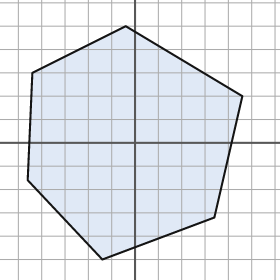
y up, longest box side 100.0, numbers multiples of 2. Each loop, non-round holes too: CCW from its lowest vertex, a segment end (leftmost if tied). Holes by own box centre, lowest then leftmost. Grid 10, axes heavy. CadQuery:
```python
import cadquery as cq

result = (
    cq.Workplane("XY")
    .moveTo(-14.0, -50.0)
    .lineTo(34.0, -32.0)
    .lineTo(46.0, 20.0)
    .lineTo(-4.0, 50.0)
    .lineTo(-44.0, 30.0)
    .lineTo(-46.0, -16.0)
    .close()
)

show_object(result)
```